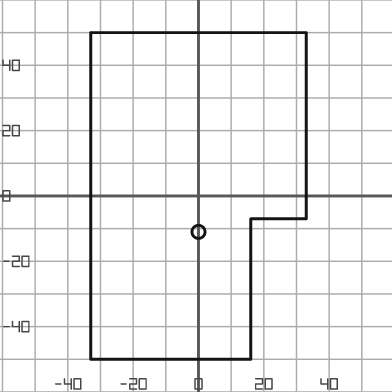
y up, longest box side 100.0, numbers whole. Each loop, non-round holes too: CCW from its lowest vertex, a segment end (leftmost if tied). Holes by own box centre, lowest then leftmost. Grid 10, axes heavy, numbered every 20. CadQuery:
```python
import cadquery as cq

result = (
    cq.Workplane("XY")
    .moveTo(-33.0, -50.0)
    .lineTo(16.0, -50.0)
    .lineTo(16.0, -7.0)
    .lineTo(33.0, -7.0)
    .lineTo(33.0, 50.0)
    .lineTo(-33.0, 50.0)
    .close()
    .moveTo(0.0, -11.0)
    .circle(2.0)
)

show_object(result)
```